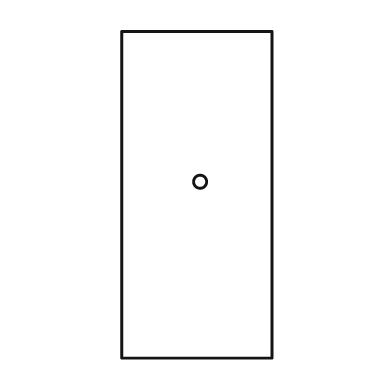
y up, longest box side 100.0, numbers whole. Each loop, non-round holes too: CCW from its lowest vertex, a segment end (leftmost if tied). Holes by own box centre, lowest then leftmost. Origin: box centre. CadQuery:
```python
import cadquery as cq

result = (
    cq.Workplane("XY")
    .moveTo(-23.0, -50.0)
    .lineTo(23.0, -50.0)
    .lineTo(23.0, 50.0)
    .lineTo(-23.0, 50.0)
    .close()
    .moveTo(1.0, 4.0)
    .circle(2.0)
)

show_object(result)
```